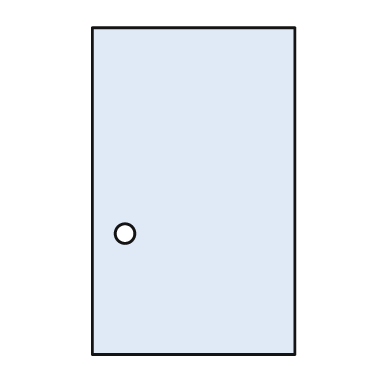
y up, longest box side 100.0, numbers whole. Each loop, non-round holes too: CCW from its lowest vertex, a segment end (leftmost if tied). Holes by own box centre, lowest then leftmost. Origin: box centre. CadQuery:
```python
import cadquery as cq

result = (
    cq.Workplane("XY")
    .moveTo(-31.0, -50.0)
    .lineTo(31.0, -50.0)
    .lineTo(31.0, 50.0)
    .lineTo(-31.0, 50.0)
    .close()
    .moveTo(-21.0, -13.0)
    .circle(3.0)
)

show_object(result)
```